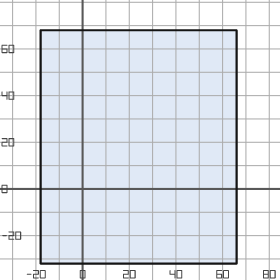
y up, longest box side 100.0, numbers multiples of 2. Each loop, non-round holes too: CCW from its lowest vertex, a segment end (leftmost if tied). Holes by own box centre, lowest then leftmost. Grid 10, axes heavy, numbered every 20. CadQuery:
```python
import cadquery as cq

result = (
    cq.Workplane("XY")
    .moveTo(-18.0, -32.0)
    .lineTo(66.0, -32.0)
    .lineTo(66.0, 68.0)
    .lineTo(-18.0, 68.0)
    .close()
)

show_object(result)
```